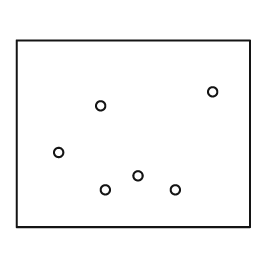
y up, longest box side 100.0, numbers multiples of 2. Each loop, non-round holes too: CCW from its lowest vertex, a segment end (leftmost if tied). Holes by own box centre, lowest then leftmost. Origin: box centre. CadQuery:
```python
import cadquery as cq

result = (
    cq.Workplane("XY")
    .moveTo(-50.0, -40.0)
    .lineTo(50.0, -40.0)
    .lineTo(50.0, 40.0)
    .lineTo(-50.0, 40.0)
    .close()
    .moveTo(-12.0, -24.0)
    .circle(2.0)
    .moveTo(18.0, -24.0)
    .circle(2.0)
    .moveTo(2.0, -18.0)
    .circle(2.0)
    .moveTo(-32.0, -8.0)
    .circle(2.0)
    .moveTo(-14.0, 12.0)
    .circle(2.0)
    .moveTo(34.0, 18.0)
    .circle(2.0)
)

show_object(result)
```